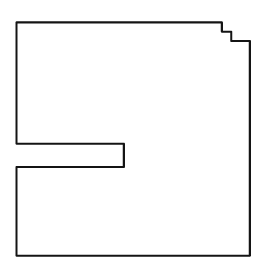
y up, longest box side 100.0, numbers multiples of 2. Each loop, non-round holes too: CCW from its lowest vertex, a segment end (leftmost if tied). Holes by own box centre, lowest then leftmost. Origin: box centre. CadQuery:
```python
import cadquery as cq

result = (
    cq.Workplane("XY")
    .moveTo(-50.0, -50.0)
    .lineTo(50.0, -50.0)
    .lineTo(50.0, 42.0)
    .lineTo(42.0, 42.0)
    .lineTo(42.0, 46.0)
    .lineTo(38.0, 46.0)
    .lineTo(38.0, 50.0)
    .lineTo(-50.0, 50.0)
    .lineTo(-50.0, -2.0)
    .lineTo(-4.0, -2.0)
    .lineTo(-4.0, -12.0)
    .lineTo(-50.0, -12.0)
    .close()
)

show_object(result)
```